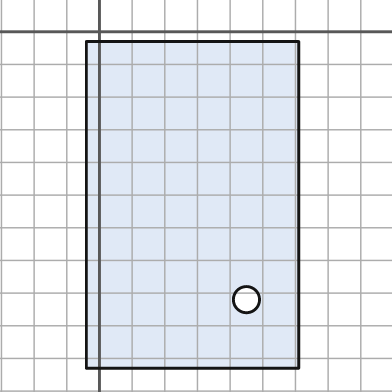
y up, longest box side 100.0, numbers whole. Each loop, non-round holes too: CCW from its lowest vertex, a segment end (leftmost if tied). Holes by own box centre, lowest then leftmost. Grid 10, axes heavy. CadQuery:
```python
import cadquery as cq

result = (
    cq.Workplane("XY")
    .moveTo(-4.0, -103.0)
    .lineTo(61.0, -103.0)
    .lineTo(61.0, -3.0)
    .lineTo(-4.0, -3.0)
    .close()
    .moveTo(45.0, -82.0)
    .circle(4.0)
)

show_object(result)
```